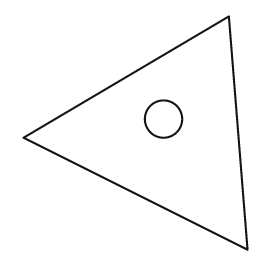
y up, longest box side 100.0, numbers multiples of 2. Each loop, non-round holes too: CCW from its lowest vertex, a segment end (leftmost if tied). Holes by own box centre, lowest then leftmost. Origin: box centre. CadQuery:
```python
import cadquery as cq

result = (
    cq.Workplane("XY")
    .moveTo(48.0, -50.0)
    .lineTo(40.0, 50.0)
    .lineTo(-48.0, -2.0)
    .close()
    .moveTo(12.0, 6.0)
    .circle(8.0)
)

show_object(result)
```